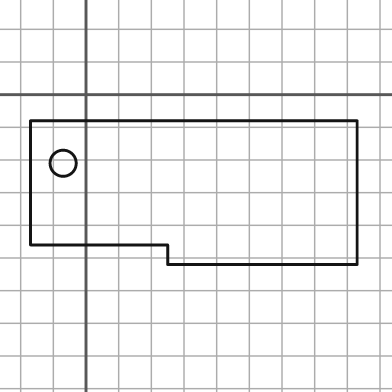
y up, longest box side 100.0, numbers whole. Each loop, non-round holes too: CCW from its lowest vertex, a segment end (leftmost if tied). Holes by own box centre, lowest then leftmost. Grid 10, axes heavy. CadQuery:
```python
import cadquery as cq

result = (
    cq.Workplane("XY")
    .moveTo(25.0, -52.0)
    .lineTo(83.0, -52.0)
    .lineTo(83.0, -8.0)
    .lineTo(-17.0, -8.0)
    .lineTo(-17.0, -46.0)
    .lineTo(25.0, -46.0)
    .close()
    .moveTo(-7.0, -21.0)
    .circle(4.0)
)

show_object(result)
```